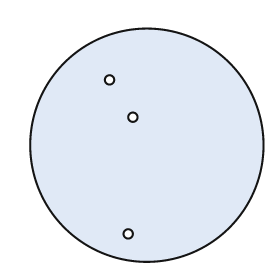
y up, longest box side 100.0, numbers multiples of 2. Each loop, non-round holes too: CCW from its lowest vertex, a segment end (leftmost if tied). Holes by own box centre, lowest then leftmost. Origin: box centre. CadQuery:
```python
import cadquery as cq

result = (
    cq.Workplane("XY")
    .moveTo(0.0, 0.0)
    .circle(50.0)
    .moveTo(-8.0, -38.0)
    .circle(2.0)
    .moveTo(-6.0, 12.0)
    .circle(2.0)
    .moveTo(-16.0, 28.0)
    .circle(2.0)
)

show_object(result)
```